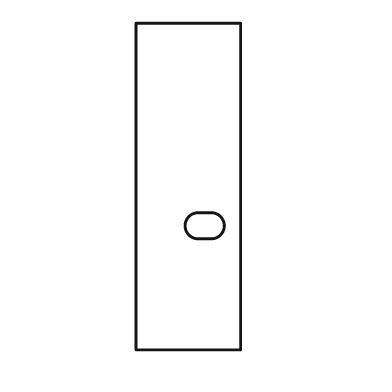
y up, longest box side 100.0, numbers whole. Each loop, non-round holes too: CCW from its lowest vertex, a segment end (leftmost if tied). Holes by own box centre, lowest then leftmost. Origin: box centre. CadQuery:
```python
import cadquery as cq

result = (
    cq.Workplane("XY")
    .moveTo(-16.0, -50.0)
    .lineTo(16.0, -50.0)
    .lineTo(16.0, 50.0)
    .lineTo(-16.0, 50.0)
    .close()
    .moveTo(3.0, -16.0)
    .lineTo(7.0, -16.0)
    .threePointArc((11.0, -12.0), (7.0, -8.0))
    .lineTo(3.0, -8.0)
    .threePointArc((-1.0, -12.0), (3.0, -16.0))
    .close()
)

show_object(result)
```